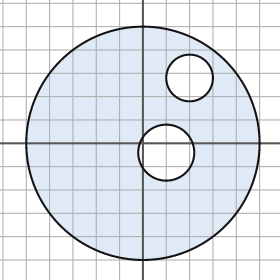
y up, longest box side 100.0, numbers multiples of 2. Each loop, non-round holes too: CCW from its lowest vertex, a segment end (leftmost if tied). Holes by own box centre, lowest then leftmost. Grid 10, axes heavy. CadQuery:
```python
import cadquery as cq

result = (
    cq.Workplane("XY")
    .moveTo(0.0, 0.0)
    .circle(50.0)
    .moveTo(10.0, -4.0)
    .circle(12.0)
    .moveTo(20.0, 28.0)
    .circle(10.0)
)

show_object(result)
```